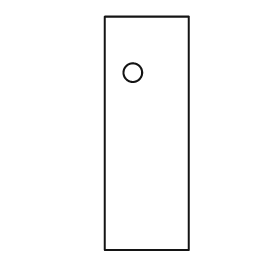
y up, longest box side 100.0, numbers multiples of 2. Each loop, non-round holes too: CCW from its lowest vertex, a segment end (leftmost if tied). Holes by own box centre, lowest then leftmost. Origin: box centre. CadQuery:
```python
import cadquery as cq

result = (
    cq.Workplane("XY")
    .moveTo(-18.0, -50.0)
    .lineTo(18.0, -50.0)
    .lineTo(18.0, 50.0)
    .lineTo(-18.0, 50.0)
    .close()
    .moveTo(-6.0, 26.0)
    .circle(4.0)
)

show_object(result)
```